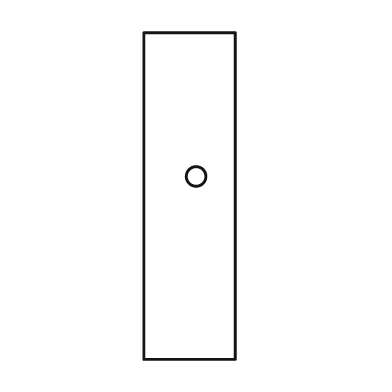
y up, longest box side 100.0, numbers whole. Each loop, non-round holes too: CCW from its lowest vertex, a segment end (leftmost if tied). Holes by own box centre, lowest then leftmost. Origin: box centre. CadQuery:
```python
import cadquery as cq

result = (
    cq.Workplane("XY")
    .moveTo(-14.0, -50.0)
    .lineTo(14.0, -50.0)
    .lineTo(14.0, 50.0)
    .lineTo(-14.0, 50.0)
    .close()
    .moveTo(2.0, 6.0)
    .circle(3.0)
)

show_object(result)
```